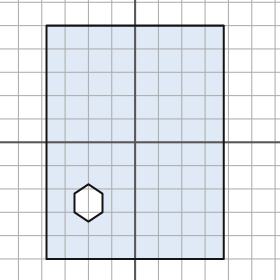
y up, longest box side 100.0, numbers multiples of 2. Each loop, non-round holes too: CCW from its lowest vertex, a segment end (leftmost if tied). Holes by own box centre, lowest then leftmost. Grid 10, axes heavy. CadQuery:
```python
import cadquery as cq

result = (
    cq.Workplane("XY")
    .moveTo(-38.0, -50.0)
    .lineTo(38.0, -50.0)
    .lineTo(38.0, 50.0)
    .lineTo(-38.0, 50.0)
    .close()
    .moveTo(-20.0, -34.0)
    .lineTo(-14.0, -30.0)
    .lineTo(-14.0, -22.0)
    .lineTo(-20.0, -18.0)
    .lineTo(-26.0, -22.0)
    .lineTo(-26.0, -30.0)
    .close()
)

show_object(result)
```